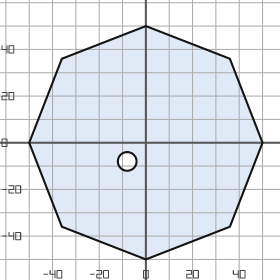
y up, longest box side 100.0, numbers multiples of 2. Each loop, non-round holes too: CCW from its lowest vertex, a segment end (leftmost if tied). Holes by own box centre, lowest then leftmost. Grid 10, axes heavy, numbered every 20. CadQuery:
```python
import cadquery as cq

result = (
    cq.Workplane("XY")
    .moveTo(0.0, -50.0)
    .lineTo(36.0, -36.0)
    .lineTo(50.0, 0.0)
    .lineTo(36.0, 36.0)
    .lineTo(0.0, 50.0)
    .lineTo(-36.0, 36.0)
    .lineTo(-50.0, 0.0)
    .lineTo(-36.0, -36.0)
    .close()
    .moveTo(-8.0, -8.0)
    .circle(4.0)
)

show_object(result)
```